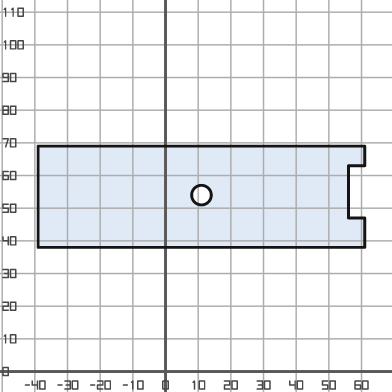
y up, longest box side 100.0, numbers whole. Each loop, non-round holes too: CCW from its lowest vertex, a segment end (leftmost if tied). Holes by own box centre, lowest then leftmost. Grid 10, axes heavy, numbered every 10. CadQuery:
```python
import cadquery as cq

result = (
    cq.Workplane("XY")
    .moveTo(-39.0, 38.0)
    .lineTo(61.0, 38.0)
    .lineTo(61.0, 47.0)
    .lineTo(56.0, 47.0)
    .lineTo(56.0, 63.0)
    .lineTo(61.0, 63.0)
    .lineTo(61.0, 69.0)
    .lineTo(-39.0, 69.0)
    .close()
    .moveTo(11.0, 54.0)
    .circle(3.0)
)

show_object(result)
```